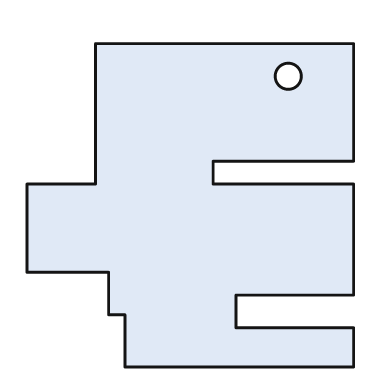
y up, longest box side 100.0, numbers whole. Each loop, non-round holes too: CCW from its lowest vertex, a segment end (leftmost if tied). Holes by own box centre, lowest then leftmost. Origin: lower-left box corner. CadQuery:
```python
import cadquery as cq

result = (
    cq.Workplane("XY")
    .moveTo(30.0, 0.0)
    .lineTo(100.0, 0.0)
    .lineTo(100.0, 12.0)
    .lineTo(64.0, 12.0)
    .lineTo(64.0, 22.0)
    .lineTo(100.0, 22.0)
    .lineTo(100.0, 56.0)
    .lineTo(57.0, 56.0)
    .lineTo(57.0, 63.0)
    .lineTo(100.0, 63.0)
    .lineTo(100.0, 99.0)
    .lineTo(21.0, 99.0)
    .lineTo(21.0, 56.0)
    .lineTo(0.0, 56.0)
    .lineTo(0.0, 29.0)
    .lineTo(25.0, 29.0)
    .lineTo(25.0, 16.0)
    .lineTo(30.0, 16.0)
    .close()
    .moveTo(80.0, 89.0)
    .circle(4.0)
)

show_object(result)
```